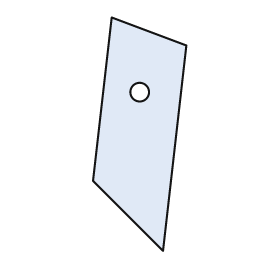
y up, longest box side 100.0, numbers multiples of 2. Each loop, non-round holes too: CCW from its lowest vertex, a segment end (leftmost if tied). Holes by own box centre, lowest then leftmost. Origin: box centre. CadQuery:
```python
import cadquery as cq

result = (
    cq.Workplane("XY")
    .moveTo(10.0, -50.0)
    .lineTo(20.0, 38.0)
    .lineTo(-12.0, 50.0)
    .lineTo(-20.0, -20.0)
    .close()
    .moveTo(0.0, 18.0)
    .circle(4.0)
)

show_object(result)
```